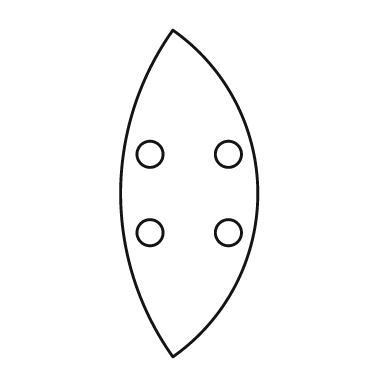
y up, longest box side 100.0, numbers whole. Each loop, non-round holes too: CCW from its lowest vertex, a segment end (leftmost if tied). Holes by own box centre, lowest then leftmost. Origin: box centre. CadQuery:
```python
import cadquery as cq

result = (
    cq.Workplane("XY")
    .moveTo(-5.0, -50.0)
    .threePointArc((21.0, 0.0), (-5.0, 50.0))
    .threePointArc((-21.0, 0.0), (-5.0, -50.0))
    .close()
    .moveTo(-12.0, -12.0)
    .circle(4.0)
    .moveTo(12.0, -12.0)
    .circle(4.0)
    .moveTo(-12.0, 12.0)
    .circle(4.0)
    .moveTo(12.0, 12.0)
    .circle(4.0)
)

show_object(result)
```